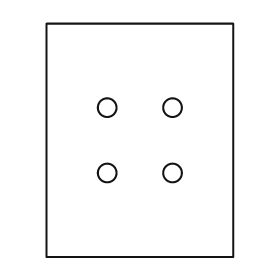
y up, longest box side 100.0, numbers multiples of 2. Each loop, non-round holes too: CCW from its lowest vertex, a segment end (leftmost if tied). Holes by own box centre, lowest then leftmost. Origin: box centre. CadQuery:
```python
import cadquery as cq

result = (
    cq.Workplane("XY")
    .moveTo(-40.0, -50.0)
    .lineTo(40.0, -50.0)
    .lineTo(40.0, 50.0)
    .lineTo(-40.0, 50.0)
    .close()
    .moveTo(-14.0, -14.0)
    .circle(4.0)
    .moveTo(14.0, -14.0)
    .circle(4.0)
    .moveTo(-14.0, 14.0)
    .circle(4.0)
    .moveTo(14.0, 14.0)
    .circle(4.0)
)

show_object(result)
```